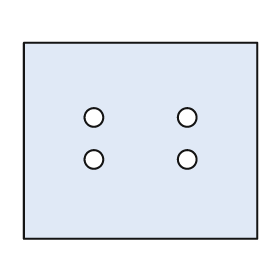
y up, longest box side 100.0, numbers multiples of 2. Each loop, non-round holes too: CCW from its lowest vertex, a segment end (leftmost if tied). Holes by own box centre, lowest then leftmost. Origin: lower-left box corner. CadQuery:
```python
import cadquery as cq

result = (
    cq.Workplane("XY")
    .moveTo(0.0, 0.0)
    .lineTo(100.0, 0.0)
    .lineTo(100.0, 84.0)
    .lineTo(0.0, 84.0)
    .close()
    .moveTo(30.0, 34.0)
    .circle(4.0)
    .moveTo(70.0, 34.0)
    .circle(4.0)
    .moveTo(30.0, 52.0)
    .circle(4.0)
    .moveTo(70.0, 52.0)
    .circle(4.0)
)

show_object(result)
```